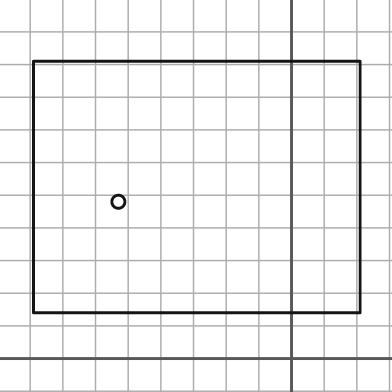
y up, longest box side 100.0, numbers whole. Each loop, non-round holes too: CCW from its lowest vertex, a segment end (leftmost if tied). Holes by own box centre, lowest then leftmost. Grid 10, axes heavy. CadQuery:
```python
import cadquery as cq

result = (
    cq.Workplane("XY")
    .moveTo(-79.0, 14.0)
    .lineTo(21.0, 14.0)
    .lineTo(21.0, 91.0)
    .lineTo(-79.0, 91.0)
    .close()
    .moveTo(-53.0, 48.0)
    .circle(2.0)
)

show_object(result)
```